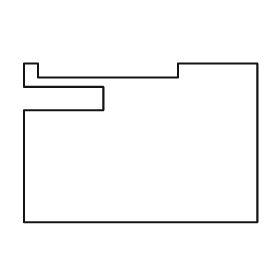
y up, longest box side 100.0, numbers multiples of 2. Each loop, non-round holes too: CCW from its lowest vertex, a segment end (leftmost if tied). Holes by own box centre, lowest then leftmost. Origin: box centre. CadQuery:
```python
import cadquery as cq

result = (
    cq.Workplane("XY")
    .moveTo(-50.0, -34.0)
    .lineTo(50.0, -34.0)
    .lineTo(50.0, 34.0)
    .lineTo(16.0, 34.0)
    .lineTo(16.0, 28.0)
    .lineTo(-44.0, 28.0)
    .lineTo(-44.0, 34.0)
    .lineTo(-50.0, 34.0)
    .lineTo(-50.0, 24.0)
    .lineTo(-16.0, 24.0)
    .lineTo(-16.0, 14.0)
    .lineTo(-50.0, 14.0)
    .close()
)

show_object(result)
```